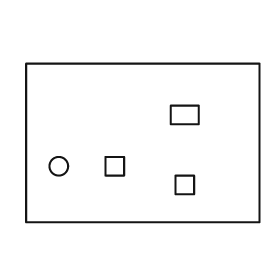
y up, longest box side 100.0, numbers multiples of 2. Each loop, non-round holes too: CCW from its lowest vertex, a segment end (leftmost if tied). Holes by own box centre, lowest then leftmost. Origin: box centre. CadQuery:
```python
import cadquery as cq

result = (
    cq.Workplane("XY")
    .moveTo(-50.0, -34.0)
    .lineTo(50.0, -34.0)
    .lineTo(50.0, 34.0)
    .lineTo(-50.0, 34.0)
    .close()
    .moveTo(14.0, -22.0)
    .lineTo(22.0, -22.0)
    .lineTo(22.0, -14.0)
    .lineTo(14.0, -14.0)
    .close()
    .moveTo(-36.0, -10.0)
    .circle(4.0)
    .moveTo(-16.0, -14.0)
    .lineTo(-8.0, -14.0)
    .lineTo(-8.0, -6.0)
    .lineTo(-16.0, -6.0)
    .close()
    .moveTo(12.0, 8.0)
    .lineTo(24.0, 8.0)
    .lineTo(24.0, 16.0)
    .lineTo(12.0, 16.0)
    .close()
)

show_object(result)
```